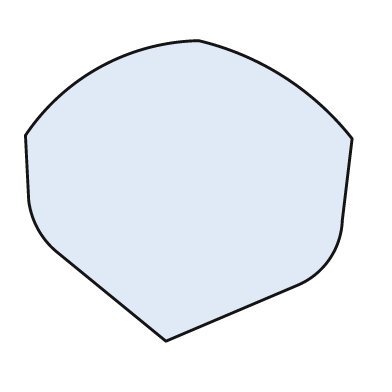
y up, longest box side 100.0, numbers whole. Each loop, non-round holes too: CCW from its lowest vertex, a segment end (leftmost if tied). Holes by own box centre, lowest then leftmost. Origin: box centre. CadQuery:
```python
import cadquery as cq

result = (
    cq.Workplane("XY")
    .moveTo(-7.0, -46.0)
    .lineTo(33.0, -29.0)
    .threePointArc((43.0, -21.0), (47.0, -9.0))
    .lineTo(50.0, 16.0)
    .threePointArc((29.0, 35.0), (3.0, 46.0))
    .threePointArc((-27.0, 38.0), (-50.0, 17.0))
    .lineTo(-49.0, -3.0)
    .threePointArc((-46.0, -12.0), (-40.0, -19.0))
    .close()
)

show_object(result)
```